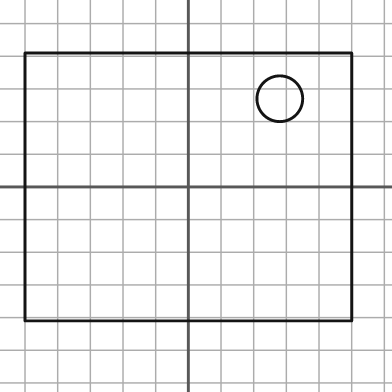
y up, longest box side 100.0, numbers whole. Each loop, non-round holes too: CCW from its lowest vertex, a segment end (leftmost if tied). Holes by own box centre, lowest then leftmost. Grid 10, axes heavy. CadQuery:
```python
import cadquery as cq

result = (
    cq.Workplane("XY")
    .moveTo(-50.0, -41.0)
    .lineTo(50.0, -41.0)
    .lineTo(50.0, 41.0)
    .lineTo(-50.0, 41.0)
    .close()
    .moveTo(28.0, 27.0)
    .circle(7.0)
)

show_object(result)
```